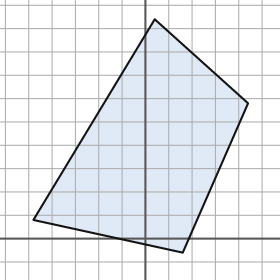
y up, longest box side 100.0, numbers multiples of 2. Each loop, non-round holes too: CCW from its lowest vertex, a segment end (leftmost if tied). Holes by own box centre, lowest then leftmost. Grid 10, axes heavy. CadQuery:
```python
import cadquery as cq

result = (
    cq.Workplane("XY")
    .moveTo(16.0, -6.0)
    .lineTo(44.0, 58.0)
    .lineTo(4.0, 94.0)
    .lineTo(-48.0, 8.0)
    .close()
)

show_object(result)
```